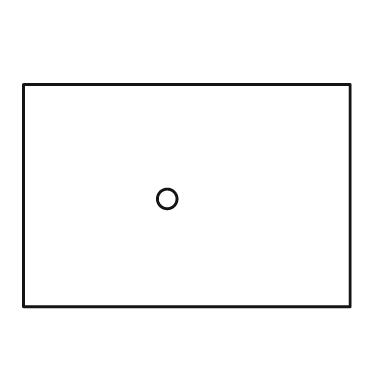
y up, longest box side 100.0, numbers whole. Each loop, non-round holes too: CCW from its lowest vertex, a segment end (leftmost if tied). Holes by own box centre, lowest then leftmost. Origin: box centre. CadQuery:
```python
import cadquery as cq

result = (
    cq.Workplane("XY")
    .moveTo(-50.0, -34.0)
    .lineTo(50.0, -34.0)
    .lineTo(50.0, 34.0)
    .lineTo(-50.0, 34.0)
    .close()
    .moveTo(-6.0, -1.0)
    .circle(3.0)
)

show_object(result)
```